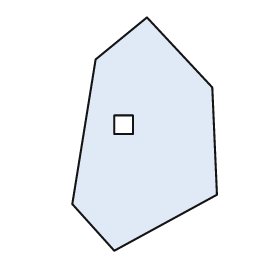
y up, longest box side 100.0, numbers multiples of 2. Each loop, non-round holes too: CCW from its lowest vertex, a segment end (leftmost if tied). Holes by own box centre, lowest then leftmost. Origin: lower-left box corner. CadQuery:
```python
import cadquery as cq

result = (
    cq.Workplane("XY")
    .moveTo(18.0, 0.0)
    .lineTo(62.0, 24.0)
    .lineTo(60.0, 70.0)
    .lineTo(32.0, 100.0)
    .lineTo(10.0, 82.0)
    .lineTo(0.0, 20.0)
    .close()
    .moveTo(18.0, 50.0)
    .lineTo(26.0, 50.0)
    .lineTo(26.0, 58.0)
    .lineTo(18.0, 58.0)
    .close()
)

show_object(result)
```